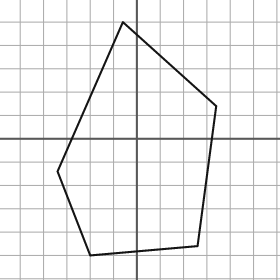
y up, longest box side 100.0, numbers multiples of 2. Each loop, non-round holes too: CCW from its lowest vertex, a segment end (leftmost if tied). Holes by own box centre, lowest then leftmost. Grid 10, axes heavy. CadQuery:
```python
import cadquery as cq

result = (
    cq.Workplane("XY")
    .moveTo(-20.0, -50.0)
    .lineTo(26.0, -46.0)
    .lineTo(34.0, 14.0)
    .lineTo(-6.0, 50.0)
    .lineTo(-34.0, -14.0)
    .close()
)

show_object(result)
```